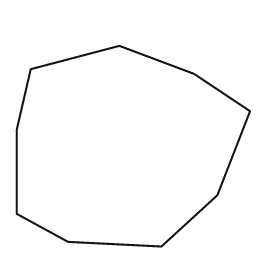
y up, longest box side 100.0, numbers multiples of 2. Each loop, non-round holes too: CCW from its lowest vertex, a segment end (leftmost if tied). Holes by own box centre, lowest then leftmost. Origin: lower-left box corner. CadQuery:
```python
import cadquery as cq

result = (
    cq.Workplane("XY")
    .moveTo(62.0, 0.0)
    .lineTo(86.0, 22.0)
    .lineTo(100.0, 58.0)
    .lineTo(76.0, 74.0)
    .lineTo(44.0, 86.0)
    .lineTo(6.0, 76.0)
    .lineTo(0.0, 50.0)
    .lineTo(0.0, 14.0)
    .lineTo(22.0, 2.0)
    .close()
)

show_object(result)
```